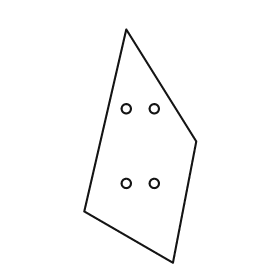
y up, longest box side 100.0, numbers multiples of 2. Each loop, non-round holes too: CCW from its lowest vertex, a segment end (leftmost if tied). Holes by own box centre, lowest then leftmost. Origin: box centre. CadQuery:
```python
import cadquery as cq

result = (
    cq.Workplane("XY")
    .moveTo(14.0, -50.0)
    .lineTo(24.0, 2.0)
    .lineTo(-6.0, 50.0)
    .lineTo(-24.0, -28.0)
    .close()
    .moveTo(-6.0, -16.0)
    .circle(2.0)
    .moveTo(6.0, -16.0)
    .circle(2.0)
    .moveTo(-6.0, 16.0)
    .circle(2.0)
    .moveTo(6.0, 16.0)
    .circle(2.0)
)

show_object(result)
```